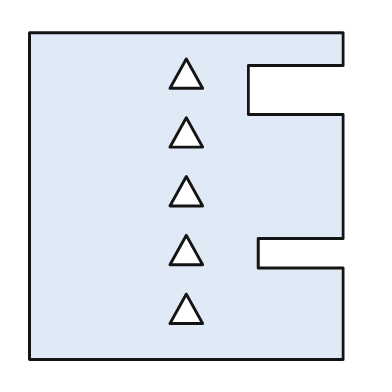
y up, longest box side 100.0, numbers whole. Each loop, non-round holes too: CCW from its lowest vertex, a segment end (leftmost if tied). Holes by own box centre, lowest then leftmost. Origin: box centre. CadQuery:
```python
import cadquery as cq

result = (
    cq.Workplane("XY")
    .moveTo(-48.0, -50.0)
    .lineTo(48.0, -50.0)
    .lineTo(48.0, -22.0)
    .lineTo(22.0, -22.0)
    .lineTo(22.0, -13.0)
    .lineTo(48.0, -13.0)
    .lineTo(48.0, 25.0)
    .lineTo(19.0, 25.0)
    .lineTo(19.0, 40.0)
    .lineTo(48.0, 40.0)
    .lineTo(48.0, 50.0)
    .lineTo(-48.0, 50.0)
    .close()
    .moveTo(-5.0, -39.0)
    .lineTo(5.0, -39.0)
    .lineTo(0.0, -30.0)
    .close()
    .moveTo(-5.0, -21.0)
    .lineTo(5.0, -21.0)
    .lineTo(0.0, -12.0)
    .close()
    .moveTo(-5.0, -3.0)
    .lineTo(5.0, -3.0)
    .lineTo(0.0, 6.0)
    .close()
    .moveTo(-5.0, 15.0)
    .lineTo(5.0, 15.0)
    .lineTo(0.0, 24.0)
    .close()
    .moveTo(-5.0, 33.0)
    .lineTo(5.0, 33.0)
    .lineTo(0.0, 42.0)
    .close()
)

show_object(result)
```